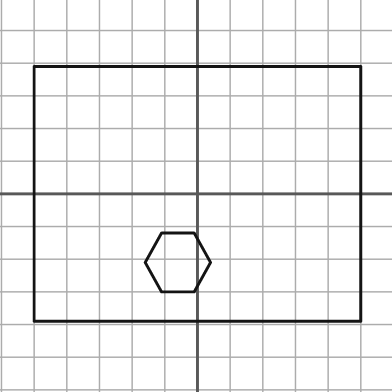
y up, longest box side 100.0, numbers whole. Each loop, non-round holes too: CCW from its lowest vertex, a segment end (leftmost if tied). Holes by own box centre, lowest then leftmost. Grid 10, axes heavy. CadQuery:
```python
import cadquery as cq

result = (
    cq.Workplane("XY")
    .moveTo(-50.0, -39.0)
    .lineTo(50.0, -39.0)
    .lineTo(50.0, 39.0)
    .lineTo(-50.0, 39.0)
    .close()
    .moveTo(-11.0, -30.0)
    .lineTo(-1.0, -30.0)
    .lineTo(4.0, -21.0)
    .lineTo(-1.0, -12.0)
    .lineTo(-11.0, -12.0)
    .lineTo(-16.0, -21.0)
    .close()
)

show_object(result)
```